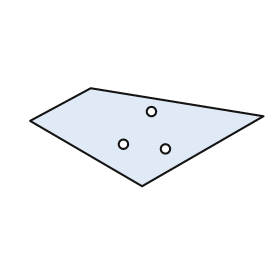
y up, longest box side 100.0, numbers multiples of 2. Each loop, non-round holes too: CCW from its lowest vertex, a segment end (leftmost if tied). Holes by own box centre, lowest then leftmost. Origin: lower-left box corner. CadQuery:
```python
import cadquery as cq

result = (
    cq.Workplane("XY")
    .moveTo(48.0, 0.0)
    .lineTo(100.0, 30.0)
    .lineTo(26.0, 42.0)
    .lineTo(0.0, 28.0)
    .close()
    .moveTo(58.0, 16.0)
    .circle(2.0)
    .moveTo(40.0, 18.0)
    .circle(2.0)
    .moveTo(52.0, 32.0)
    .circle(2.0)
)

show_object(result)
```